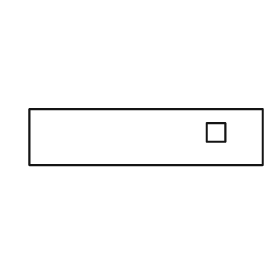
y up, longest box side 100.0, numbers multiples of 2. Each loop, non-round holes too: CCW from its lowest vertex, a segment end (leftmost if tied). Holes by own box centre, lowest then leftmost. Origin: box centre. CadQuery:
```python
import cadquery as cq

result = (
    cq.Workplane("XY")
    .moveTo(-50.0, -12.0)
    .lineTo(50.0, -12.0)
    .lineTo(50.0, 12.0)
    .lineTo(-50.0, 12.0)
    .close()
    .moveTo(26.0, -2.0)
    .lineTo(34.0, -2.0)
    .lineTo(34.0, 6.0)
    .lineTo(26.0, 6.0)
    .close()
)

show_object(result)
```